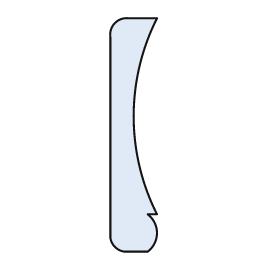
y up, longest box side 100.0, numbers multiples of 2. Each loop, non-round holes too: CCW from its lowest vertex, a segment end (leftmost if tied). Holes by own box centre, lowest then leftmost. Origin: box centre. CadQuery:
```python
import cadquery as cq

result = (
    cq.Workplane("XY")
    .moveTo(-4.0, -50.0)
    .lineTo(6.0, -50.0)
    .threePointArc((10.0, -42.0), (6.0, -34.0))
    .lineTo(10.0, -34.0)
    .threePointArc((0.0, 8.0), (10.0, 50.0))
    .lineTo(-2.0, 50.0)
    .threePointArc((-8.0, 48.0), (-10.0, 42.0))
    .lineTo(-10.0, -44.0)
    .threePointArc((-8.0, -48.0), (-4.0, -50.0))
    .close()
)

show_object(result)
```